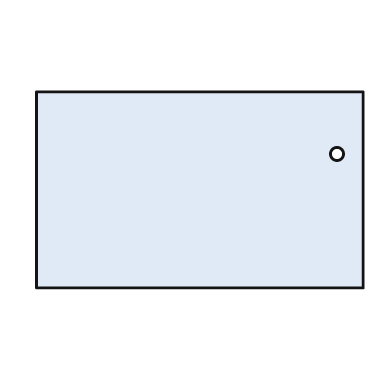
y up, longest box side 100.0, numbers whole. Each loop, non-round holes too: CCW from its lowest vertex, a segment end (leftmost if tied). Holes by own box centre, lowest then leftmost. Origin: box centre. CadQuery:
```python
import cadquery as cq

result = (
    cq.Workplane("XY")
    .moveTo(-50.0, -30.0)
    .lineTo(50.0, -30.0)
    .lineTo(50.0, 30.0)
    .lineTo(-50.0, 30.0)
    .close()
    .moveTo(42.0, 11.0)
    .circle(2.0)
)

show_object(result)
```